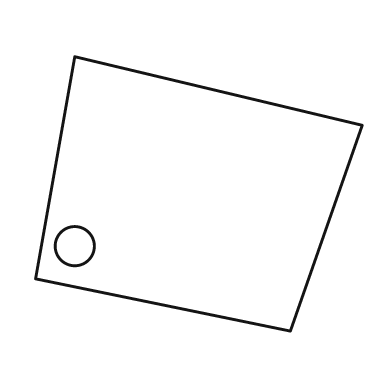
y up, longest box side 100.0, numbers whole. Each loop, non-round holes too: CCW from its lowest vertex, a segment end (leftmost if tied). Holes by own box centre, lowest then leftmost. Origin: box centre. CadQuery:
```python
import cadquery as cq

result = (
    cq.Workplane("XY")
    .moveTo(28.0, -42.0)
    .lineTo(50.0, 21.0)
    .lineTo(-38.0, 42.0)
    .lineTo(-50.0, -26.0)
    .close()
    .moveTo(-38.0, -16.0)
    .circle(6.0)
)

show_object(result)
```